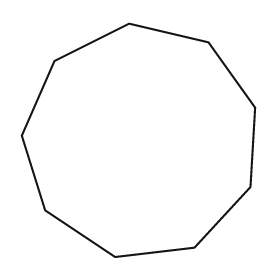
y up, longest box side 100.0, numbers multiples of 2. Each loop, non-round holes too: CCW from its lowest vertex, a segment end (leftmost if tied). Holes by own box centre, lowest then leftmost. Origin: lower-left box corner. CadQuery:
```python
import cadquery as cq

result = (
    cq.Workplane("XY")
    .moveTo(40.0, 0.0)
    .lineTo(74.0, 4.0)
    .lineTo(98.0, 30.0)
    .lineTo(100.0, 64.0)
    .lineTo(80.0, 92.0)
    .lineTo(46.0, 100.0)
    .lineTo(14.0, 84.0)
    .lineTo(0.0, 52.0)
    .lineTo(10.0, 20.0)
    .close()
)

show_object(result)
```